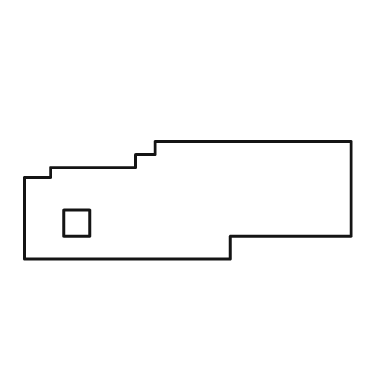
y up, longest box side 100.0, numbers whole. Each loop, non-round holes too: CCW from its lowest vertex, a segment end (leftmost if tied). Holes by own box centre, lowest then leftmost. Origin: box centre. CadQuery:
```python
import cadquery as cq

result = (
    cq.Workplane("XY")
    .moveTo(-50.0, -18.0)
    .lineTo(13.0, -18.0)
    .lineTo(13.0, -11.0)
    .lineTo(50.0, -11.0)
    .lineTo(50.0, 18.0)
    .lineTo(-10.0, 18.0)
    .lineTo(-10.0, 14.0)
    .lineTo(-16.0, 14.0)
    .lineTo(-16.0, 10.0)
    .lineTo(-42.0, 10.0)
    .lineTo(-42.0, 7.0)
    .lineTo(-50.0, 7.0)
    .close()
    .moveTo(-38.0, -11.0)
    .lineTo(-30.0, -11.0)
    .lineTo(-30.0, -3.0)
    .lineTo(-38.0, -3.0)
    .close()
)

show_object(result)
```